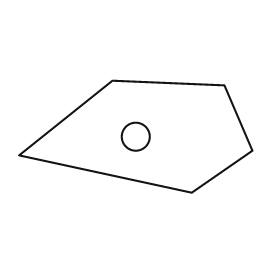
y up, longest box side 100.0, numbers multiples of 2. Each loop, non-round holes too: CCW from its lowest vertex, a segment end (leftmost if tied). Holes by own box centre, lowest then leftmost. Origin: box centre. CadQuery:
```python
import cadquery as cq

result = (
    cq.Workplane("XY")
    .moveTo(24.0, -24.0)
    .lineTo(50.0, -6.0)
    .lineTo(38.0, 22.0)
    .lineTo(-10.0, 24.0)
    .lineTo(-50.0, -8.0)
    .close()
    .moveTo(0.0, 0.0)
    .circle(6.0)
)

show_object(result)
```